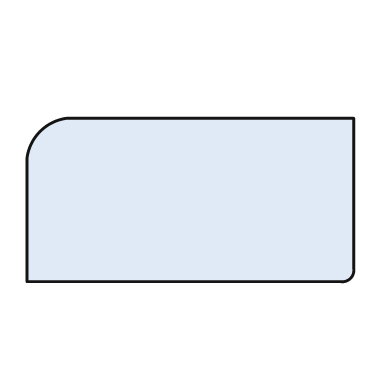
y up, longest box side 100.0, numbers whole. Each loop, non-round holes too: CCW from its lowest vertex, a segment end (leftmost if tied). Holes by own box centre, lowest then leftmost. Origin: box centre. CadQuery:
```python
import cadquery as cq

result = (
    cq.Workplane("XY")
    .moveTo(-50.0, -25.0)
    .lineTo(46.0, -25.0)
    .threePointArc((49.0, -24.0), (50.0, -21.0))
    .lineTo(50.0, 25.0)
    .lineTo(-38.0, 25.0)
    .threePointArc((-46.0, 21.0), (-50.0, 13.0))
    .close()
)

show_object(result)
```